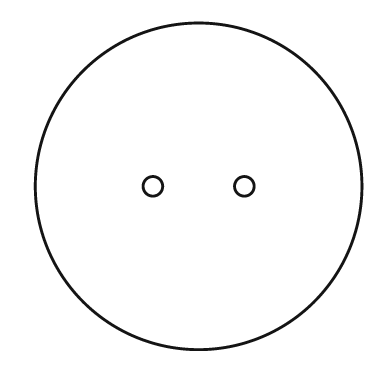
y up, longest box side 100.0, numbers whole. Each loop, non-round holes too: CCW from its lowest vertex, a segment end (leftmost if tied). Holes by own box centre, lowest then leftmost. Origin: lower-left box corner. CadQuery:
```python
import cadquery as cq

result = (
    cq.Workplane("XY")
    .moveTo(50.0, 50.0)
    .circle(50.0)
    .moveTo(36.0, 50.0)
    .circle(3.0)
    .moveTo(64.0, 50.0)
    .circle(3.0)
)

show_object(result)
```